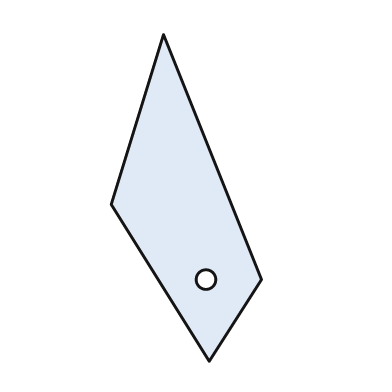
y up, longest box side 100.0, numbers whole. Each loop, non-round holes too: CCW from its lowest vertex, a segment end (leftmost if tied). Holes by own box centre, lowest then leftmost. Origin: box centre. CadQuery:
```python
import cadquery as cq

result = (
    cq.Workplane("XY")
    .moveTo(7.0, -50.0)
    .lineTo(23.0, -25.0)
    .lineTo(-7.0, 50.0)
    .lineTo(-23.0, -2.0)
    .close()
    .moveTo(6.0, -25.0)
    .circle(3.0)
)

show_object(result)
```